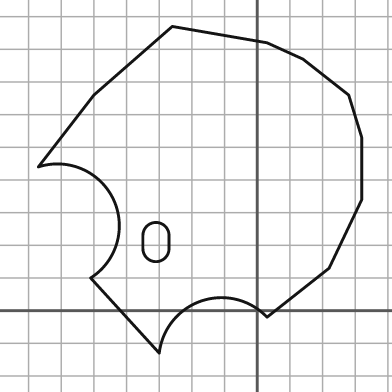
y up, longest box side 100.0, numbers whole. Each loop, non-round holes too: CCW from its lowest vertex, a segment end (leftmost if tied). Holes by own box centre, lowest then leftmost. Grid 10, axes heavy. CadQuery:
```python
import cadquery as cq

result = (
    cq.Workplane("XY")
    .moveTo(-30.0, -13.0)
    .threePointArc((-17.0, 3.0), (3.0, -2.0))
    .lineTo(22.0, 13.0)
    .lineTo(32.0, 34.0)
    .lineTo(32.0, 53.0)
    .lineTo(28.0, 66.0)
    .lineTo(14.0, 77.0)
    .lineTo(3.0, 82.0)
    .lineTo(-26.0, 87.0)
    .lineTo(-50.0, 66.0)
    .lineTo(-67.0, 44.0)
    .threePointArc((-44.0, 34.0), (-51.0, 10.0))
    .close()
    .moveTo(-35.0, 19.0)
    .threePointArc((-31.0, 15.0), (-27.0, 19.0))
    .lineTo(-27.0, 23.0)
    .threePointArc((-31.0, 27.0), (-35.0, 23.0))
    .close()
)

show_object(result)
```